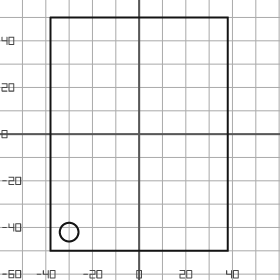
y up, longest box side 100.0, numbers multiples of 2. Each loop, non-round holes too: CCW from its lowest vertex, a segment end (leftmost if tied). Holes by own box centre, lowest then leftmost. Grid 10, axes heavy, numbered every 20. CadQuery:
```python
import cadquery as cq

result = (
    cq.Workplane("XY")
    .moveTo(-38.0, -50.0)
    .lineTo(38.0, -50.0)
    .lineTo(38.0, 50.0)
    .lineTo(-38.0, 50.0)
    .close()
    .moveTo(-30.0, -42.0)
    .circle(4.0)
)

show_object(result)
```